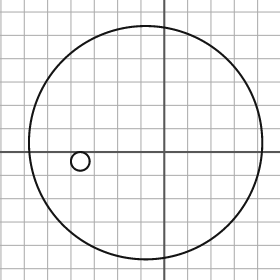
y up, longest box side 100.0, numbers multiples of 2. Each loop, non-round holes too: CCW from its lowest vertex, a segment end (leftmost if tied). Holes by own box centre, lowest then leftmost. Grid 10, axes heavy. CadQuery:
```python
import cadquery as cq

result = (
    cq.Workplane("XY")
    .moveTo(-8.0, 4.0)
    .circle(50.0)
    .moveTo(-36.0, -4.0)
    .circle(4.0)
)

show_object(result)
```